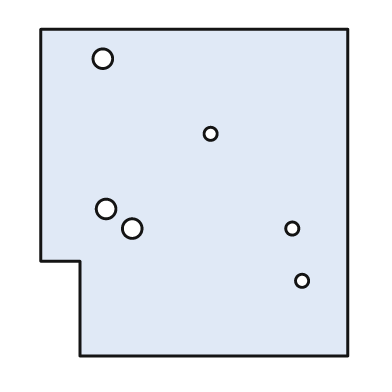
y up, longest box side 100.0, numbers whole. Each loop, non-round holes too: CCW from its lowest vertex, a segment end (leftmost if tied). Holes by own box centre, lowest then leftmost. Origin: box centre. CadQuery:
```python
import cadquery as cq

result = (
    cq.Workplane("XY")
    .moveTo(-35.0, -50.0)
    .lineTo(47.0, -50.0)
    .lineTo(47.0, 50.0)
    .lineTo(-47.0, 50.0)
    .lineTo(-47.0, -21.0)
    .lineTo(-35.0, -21.0)
    .close()
    .moveTo(33.0, -27.0)
    .circle(2.0)
    .moveTo(-19.0, -11.0)
    .circle(3.0)
    .moveTo(30.0, -11.0)
    .circle(2.0)
    .moveTo(-27.0, -5.0)
    .circle(3.0)
    .moveTo(5.0, 18.0)
    .circle(2.0)
    .moveTo(-28.0, 41.0)
    .circle(3.0)
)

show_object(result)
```